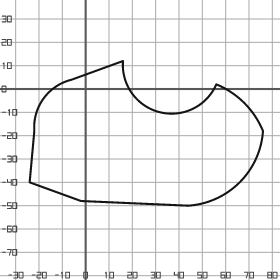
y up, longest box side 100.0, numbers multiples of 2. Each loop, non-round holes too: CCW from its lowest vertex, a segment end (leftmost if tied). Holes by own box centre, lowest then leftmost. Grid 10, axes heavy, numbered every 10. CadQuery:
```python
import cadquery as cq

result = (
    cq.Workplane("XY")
    .moveTo(44.0, -50.0)
    .threePointArc((66.0, -40.0), (76.0, -18.0))
    .threePointArc((68.0, -6.0), (56.0, 2.0))
    .threePointArc((32.0, -10.0), (16.0, 12.0))
    .lineTo(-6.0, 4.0)
    .threePointArc((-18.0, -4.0), (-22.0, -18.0))
    .lineTo(-24.0, -40.0)
    .lineTo(-2.0, -48.0)
    .close()
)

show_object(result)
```